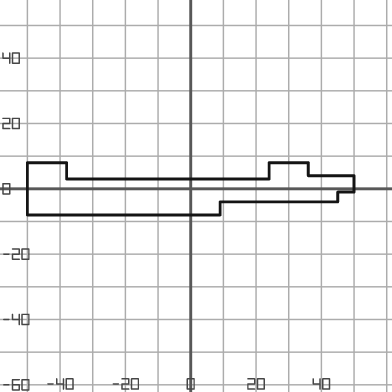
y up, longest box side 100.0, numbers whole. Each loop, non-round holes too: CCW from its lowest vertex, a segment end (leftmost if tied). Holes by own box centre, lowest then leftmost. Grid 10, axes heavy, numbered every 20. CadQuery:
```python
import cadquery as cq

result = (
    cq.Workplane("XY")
    .moveTo(-50.0, -8.0)
    .lineTo(9.0, -8.0)
    .lineTo(9.0, -4.0)
    .lineTo(45.0, -4.0)
    .lineTo(45.0, -1.0)
    .lineTo(50.0, -1.0)
    .lineTo(50.0, 4.0)
    .lineTo(36.0, 4.0)
    .lineTo(36.0, 8.0)
    .lineTo(24.0, 8.0)
    .lineTo(24.0, 3.0)
    .lineTo(-38.0, 3.0)
    .lineTo(-38.0, 8.0)
    .lineTo(-50.0, 8.0)
    .close()
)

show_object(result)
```